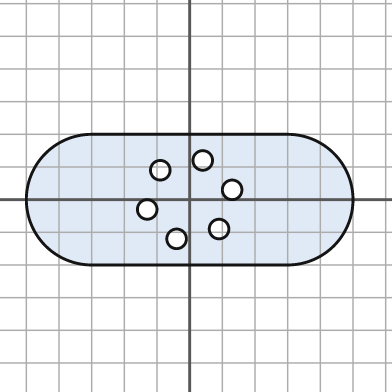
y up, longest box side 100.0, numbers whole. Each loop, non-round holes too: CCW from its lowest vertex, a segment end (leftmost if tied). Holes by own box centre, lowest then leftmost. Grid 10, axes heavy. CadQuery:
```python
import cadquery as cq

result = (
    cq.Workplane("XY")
    .moveTo(-30.0, -20.0)
    .lineTo(30.0, -20.0)
    .threePointArc((50.0, 0.0), (30.0, 20.0))
    .lineTo(-30.0, 20.0)
    .threePointArc((-50.0, 0.0), (-30.0, -20.0))
    .close()
    .moveTo(-4.0, -12.0)
    .circle(3.0)
    .moveTo(9.0, -9.0)
    .circle(3.0)
    .moveTo(-13.0, -3.0)
    .circle(3.0)
    .moveTo(13.0, 3.0)
    .circle(3.0)
    .moveTo(-9.0, 9.0)
    .circle(3.0)
    .moveTo(4.0, 12.0)
    .circle(3.0)
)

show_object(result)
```